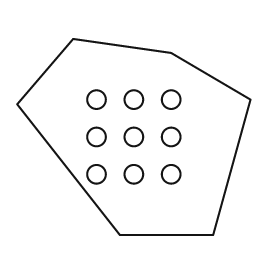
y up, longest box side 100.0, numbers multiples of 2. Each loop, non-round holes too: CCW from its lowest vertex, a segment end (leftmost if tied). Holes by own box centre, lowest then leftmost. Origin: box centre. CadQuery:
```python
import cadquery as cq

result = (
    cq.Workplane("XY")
    .moveTo(-6.0, -42.0)
    .lineTo(34.0, -42.0)
    .lineTo(50.0, 16.0)
    .lineTo(16.0, 36.0)
    .lineTo(-26.0, 42.0)
    .lineTo(-50.0, 14.0)
    .close()
    .moveTo(-16.0, -16.0)
    .circle(4.0)
    .moveTo(0.0, -16.0)
    .circle(4.0)
    .moveTo(16.0, -16.0)
    .circle(4.0)
    .moveTo(-16.0, 0.0)
    .circle(4.0)
    .moveTo(0.0, 0.0)
    .circle(4.0)
    .moveTo(16.0, 0.0)
    .circle(4.0)
    .moveTo(-16.0, 16.0)
    .circle(4.0)
    .moveTo(0.0, 16.0)
    .circle(4.0)
    .moveTo(16.0, 16.0)
    .circle(4.0)
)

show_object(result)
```